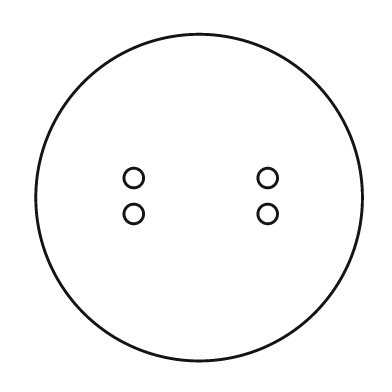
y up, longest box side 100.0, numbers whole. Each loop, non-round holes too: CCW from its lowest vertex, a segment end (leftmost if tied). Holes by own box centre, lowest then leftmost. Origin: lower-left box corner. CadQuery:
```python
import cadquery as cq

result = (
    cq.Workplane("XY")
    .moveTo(50.0, 50.0)
    .circle(50.0)
    .moveTo(30.0, 45.0)
    .circle(3.0)
    .moveTo(71.0, 45.0)
    .circle(3.0)
    .moveTo(30.0, 56.0)
    .circle(3.0)
    .moveTo(71.0, 56.0)
    .circle(3.0)
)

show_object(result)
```